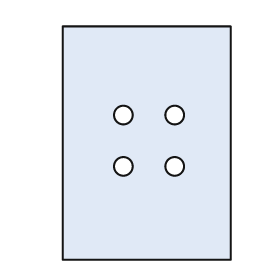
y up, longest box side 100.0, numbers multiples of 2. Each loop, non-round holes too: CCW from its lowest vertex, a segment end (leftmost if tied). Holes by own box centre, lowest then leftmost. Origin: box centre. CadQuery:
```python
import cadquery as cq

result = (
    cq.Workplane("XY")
    .moveTo(-36.0, -50.0)
    .lineTo(36.0, -50.0)
    .lineTo(36.0, 50.0)
    .lineTo(-36.0, 50.0)
    .close()
    .moveTo(-10.0, -10.0)
    .circle(4.0)
    .moveTo(12.0, -10.0)
    .circle(4.0)
    .moveTo(-10.0, 12.0)
    .circle(4.0)
    .moveTo(12.0, 12.0)
    .circle(4.0)
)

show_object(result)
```